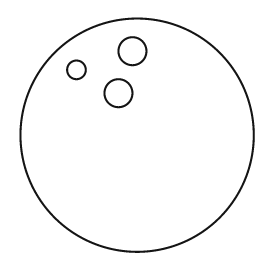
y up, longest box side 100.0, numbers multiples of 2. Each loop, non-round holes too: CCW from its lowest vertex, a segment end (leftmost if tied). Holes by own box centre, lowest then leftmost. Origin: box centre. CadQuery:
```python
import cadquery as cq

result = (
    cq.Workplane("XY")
    .moveTo(0.0, 0.0)
    .circle(50.0)
    .moveTo(-8.0, 18.0)
    .circle(6.0)
    .moveTo(-26.0, 28.0)
    .circle(4.0)
    .moveTo(-2.0, 36.0)
    .circle(6.0)
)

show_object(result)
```